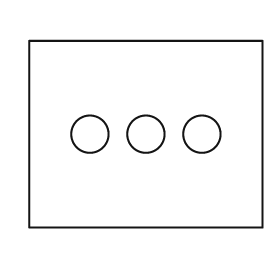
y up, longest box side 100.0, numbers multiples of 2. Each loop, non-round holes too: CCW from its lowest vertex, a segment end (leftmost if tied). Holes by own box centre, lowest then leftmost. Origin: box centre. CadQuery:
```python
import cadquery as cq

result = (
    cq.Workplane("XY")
    .moveTo(-50.0, -40.0)
    .lineTo(50.0, -40.0)
    .lineTo(50.0, 40.0)
    .lineTo(-50.0, 40.0)
    .close()
    .moveTo(-24.0, 0.0)
    .circle(8.0)
    .moveTo(0.0, 0.0)
    .circle(8.0)
    .moveTo(24.0, 0.0)
    .circle(8.0)
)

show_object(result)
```